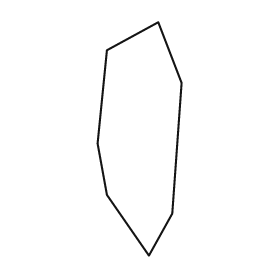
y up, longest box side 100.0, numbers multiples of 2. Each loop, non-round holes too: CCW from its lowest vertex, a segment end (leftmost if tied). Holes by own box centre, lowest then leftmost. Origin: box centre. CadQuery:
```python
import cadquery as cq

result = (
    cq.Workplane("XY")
    .moveTo(4.0, -50.0)
    .lineTo(14.0, -32.0)
    .lineTo(18.0, 24.0)
    .lineTo(8.0, 50.0)
    .lineTo(-14.0, 38.0)
    .lineTo(-18.0, -2.0)
    .lineTo(-14.0, -24.0)
    .close()
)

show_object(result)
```